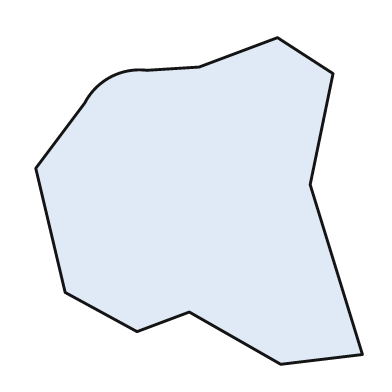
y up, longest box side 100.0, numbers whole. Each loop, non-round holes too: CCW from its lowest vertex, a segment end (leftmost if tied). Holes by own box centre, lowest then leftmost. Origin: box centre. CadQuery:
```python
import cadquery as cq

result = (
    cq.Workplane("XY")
    .moveTo(25.0, -50.0)
    .lineTo(50.0, -47.0)
    .lineTo(34.0, 5.0)
    .lineTo(41.0, 39.0)
    .lineTo(24.0, 50.0)
    .lineTo(0.0, 41.0)
    .lineTo(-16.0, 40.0)
    .threePointArc((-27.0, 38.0), (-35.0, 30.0))
    .lineTo(-50.0, 10.0)
    .lineTo(-41.0, -28.0)
    .lineTo(-19.0, -40.0)
    .lineTo(-3.0, -34.0)
    .close()
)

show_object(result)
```